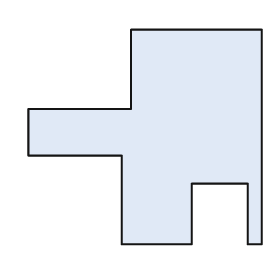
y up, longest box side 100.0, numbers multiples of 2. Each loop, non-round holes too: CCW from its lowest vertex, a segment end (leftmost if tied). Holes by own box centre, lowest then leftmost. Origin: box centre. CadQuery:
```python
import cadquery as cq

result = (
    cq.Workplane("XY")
    .moveTo(-10.0, -46.0)
    .lineTo(20.0, -46.0)
    .lineTo(20.0, -20.0)
    .lineTo(44.0, -20.0)
    .lineTo(44.0, -46.0)
    .lineTo(50.0, -46.0)
    .lineTo(50.0, 46.0)
    .lineTo(-6.0, 46.0)
    .lineTo(-6.0, 12.0)
    .lineTo(-50.0, 12.0)
    .lineTo(-50.0, -8.0)
    .lineTo(-10.0, -8.0)
    .close()
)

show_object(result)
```